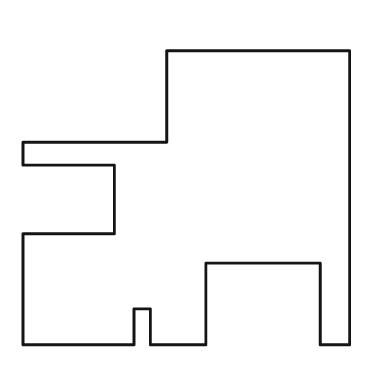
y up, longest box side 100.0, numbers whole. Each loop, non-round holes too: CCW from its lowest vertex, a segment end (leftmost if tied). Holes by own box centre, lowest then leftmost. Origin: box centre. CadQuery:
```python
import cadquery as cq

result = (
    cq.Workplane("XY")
    .moveTo(-50.0, -45.0)
    .lineTo(-16.0, -45.0)
    .lineTo(-16.0, -34.0)
    .lineTo(-11.0, -34.0)
    .lineTo(-11.0, -45.0)
    .lineTo(6.0, -45.0)
    .lineTo(6.0, -20.0)
    .lineTo(41.0, -20.0)
    .lineTo(41.0, -45.0)
    .lineTo(50.0, -45.0)
    .lineTo(50.0, 45.0)
    .lineTo(-6.0, 45.0)
    .lineTo(-6.0, 17.0)
    .lineTo(-50.0, 17.0)
    .lineTo(-50.0, 10.0)
    .lineTo(-22.0, 10.0)
    .lineTo(-22.0, -11.0)
    .lineTo(-50.0, -11.0)
    .close()
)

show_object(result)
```